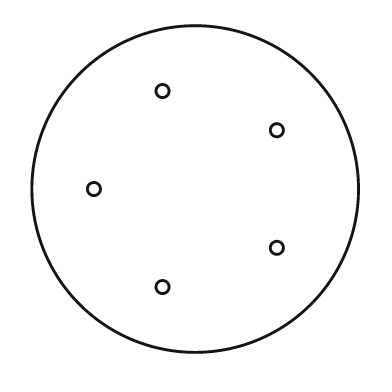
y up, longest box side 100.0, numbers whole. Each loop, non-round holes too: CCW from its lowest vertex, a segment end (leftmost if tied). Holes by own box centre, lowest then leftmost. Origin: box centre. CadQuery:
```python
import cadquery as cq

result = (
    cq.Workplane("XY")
    .moveTo(0.0, 0.0)
    .circle(50.0)
    .moveTo(-10.0, -30.0)
    .circle(2.0)
    .moveTo(25.0, -18.0)
    .circle(2.0)
    .moveTo(-31.0, 0.0)
    .circle(2.0)
    .moveTo(25.0, 18.0)
    .circle(2.0)
    .moveTo(-10.0, 30.0)
    .circle(2.0)
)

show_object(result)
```